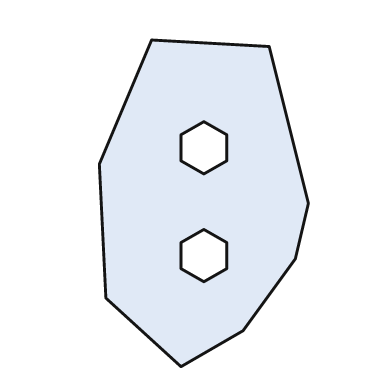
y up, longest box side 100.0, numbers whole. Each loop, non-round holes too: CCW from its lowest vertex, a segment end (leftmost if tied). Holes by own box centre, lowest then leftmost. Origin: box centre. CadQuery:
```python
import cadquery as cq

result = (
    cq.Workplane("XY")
    .moveTo(-7.0, -50.0)
    .lineTo(12.0, -39.0)
    .lineTo(28.0, -17.0)
    .lineTo(32.0, 0.0)
    .lineTo(20.0, 48.0)
    .lineTo(-16.0, 50.0)
    .lineTo(-32.0, 12.0)
    .lineTo(-30.0, -29.0)
    .close()
    .moveTo(0.0, -24.0)
    .lineTo(7.0, -20.0)
    .lineTo(7.0, -12.0)
    .lineTo(0.0, -8.0)
    .lineTo(-7.0, -12.0)
    .lineTo(-7.0, -20.0)
    .close()
    .moveTo(0.0, 9.0)
    .lineTo(7.0, 13.0)
    .lineTo(7.0, 21.0)
    .lineTo(0.0, 25.0)
    .lineTo(-7.0, 21.0)
    .lineTo(-7.0, 13.0)
    .close()
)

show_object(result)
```